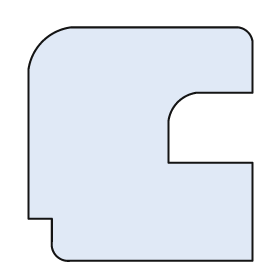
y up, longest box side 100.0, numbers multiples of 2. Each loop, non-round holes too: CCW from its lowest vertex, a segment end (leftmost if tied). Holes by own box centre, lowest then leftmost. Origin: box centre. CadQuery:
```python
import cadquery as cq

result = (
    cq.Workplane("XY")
    .moveTo(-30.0, -50.0)
    .lineTo(48.0, -50.0)
    .lineTo(48.0, -8.0)
    .lineTo(12.0, -8.0)
    .lineTo(12.0, 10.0)
    .threePointArc((16.0, 18.0), (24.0, 22.0))
    .lineTo(48.0, 22.0)
    .lineTo(48.0, 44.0)
    .threePointArc((46.0, 48.0), (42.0, 50.0))
    .lineTo(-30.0, 50.0)
    .threePointArc((-42.0, 44.0), (-48.0, 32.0))
    .lineTo(-48.0, -32.0)
    .lineTo(-38.0, -32.0)
    .lineTo(-38.0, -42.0)
    .threePointArc((-36.0, -48.0), (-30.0, -50.0))
    .close()
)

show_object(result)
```